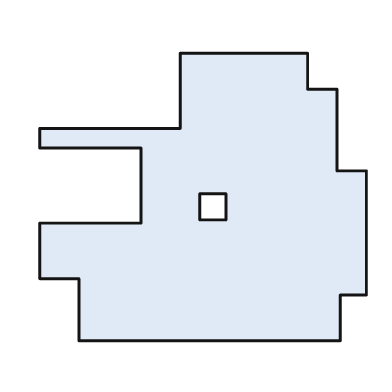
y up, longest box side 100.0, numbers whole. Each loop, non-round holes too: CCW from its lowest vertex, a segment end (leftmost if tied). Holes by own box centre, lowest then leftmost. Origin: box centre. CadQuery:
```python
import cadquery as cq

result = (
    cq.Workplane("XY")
    .moveTo(-38.0, -44.0)
    .lineTo(42.0, -44.0)
    .lineTo(42.0, -30.0)
    .lineTo(50.0, -30.0)
    .lineTo(50.0, 8.0)
    .lineTo(41.0, 8.0)
    .lineTo(41.0, 33.0)
    .lineTo(32.0, 33.0)
    .lineTo(32.0, 44.0)
    .lineTo(-7.0, 44.0)
    .lineTo(-7.0, 21.0)
    .lineTo(-50.0, 21.0)
    .lineTo(-50.0, 15.0)
    .lineTo(-19.0, 15.0)
    .lineTo(-19.0, -8.0)
    .lineTo(-50.0, -8.0)
    .lineTo(-50.0, -25.0)
    .lineTo(-38.0, -25.0)
    .close()
    .moveTo(-1.0, -7.0)
    .lineTo(7.0, -7.0)
    .lineTo(7.0, 1.0)
    .lineTo(-1.0, 1.0)
    .close()
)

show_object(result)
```